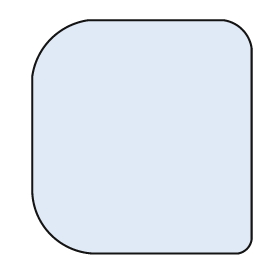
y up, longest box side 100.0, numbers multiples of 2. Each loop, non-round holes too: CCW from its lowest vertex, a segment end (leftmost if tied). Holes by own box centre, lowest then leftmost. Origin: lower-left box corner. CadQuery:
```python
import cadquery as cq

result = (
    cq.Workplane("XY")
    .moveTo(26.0, 0.0)
    .lineTo(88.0, 0.0)
    .threePointArc((92.0, 2.0), (94.0, 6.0))
    .lineTo(94.0, 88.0)
    .threePointArc((90.0, 96.0), (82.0, 100.0))
    .lineTo(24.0, 100.0)
    .threePointArc((8.0, 92.0), (0.0, 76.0))
    .lineTo(0.0, 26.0)
    .threePointArc((8.0, 8.0), (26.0, 0.0))
    .close()
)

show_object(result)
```